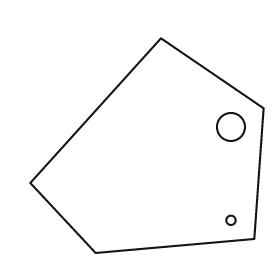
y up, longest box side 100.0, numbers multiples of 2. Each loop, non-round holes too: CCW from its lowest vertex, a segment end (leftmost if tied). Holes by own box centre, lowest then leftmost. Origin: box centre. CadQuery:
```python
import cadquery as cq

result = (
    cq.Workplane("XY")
    .moveTo(-22.0, -46.0)
    .lineTo(46.0, -40.0)
    .lineTo(50.0, 16.0)
    .lineTo(6.0, 46.0)
    .lineTo(-50.0, -16.0)
    .close()
    .moveTo(36.0, -32.0)
    .circle(2.0)
    .moveTo(36.0, 8.0)
    .circle(6.0)
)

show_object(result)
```